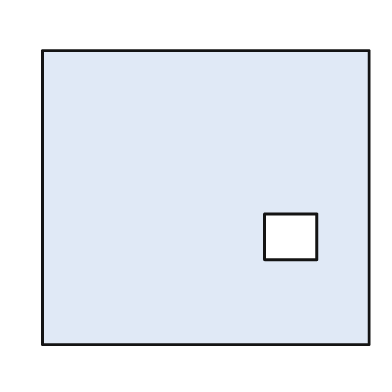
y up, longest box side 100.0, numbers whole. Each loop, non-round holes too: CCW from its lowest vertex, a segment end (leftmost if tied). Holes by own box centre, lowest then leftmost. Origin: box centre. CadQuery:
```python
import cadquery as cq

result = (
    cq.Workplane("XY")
    .moveTo(-50.0, -45.0)
    .lineTo(50.0, -45.0)
    .lineTo(50.0, 45.0)
    .lineTo(-50.0, 45.0)
    .close()
    .moveTo(18.0, -19.0)
    .lineTo(34.0, -19.0)
    .lineTo(34.0, -5.0)
    .lineTo(18.0, -5.0)
    .close()
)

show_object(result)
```